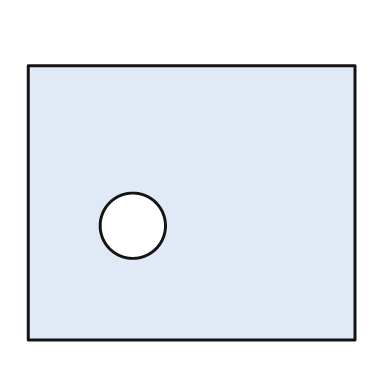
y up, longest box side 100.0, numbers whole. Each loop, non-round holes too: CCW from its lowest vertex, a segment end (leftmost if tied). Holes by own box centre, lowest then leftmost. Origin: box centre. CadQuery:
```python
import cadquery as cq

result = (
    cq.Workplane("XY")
    .moveTo(-50.0, -42.0)
    .lineTo(50.0, -42.0)
    .lineTo(50.0, 42.0)
    .lineTo(-50.0, 42.0)
    .close()
    .moveTo(-18.0, -7.0)
    .circle(10.0)
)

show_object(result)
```